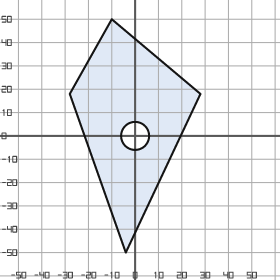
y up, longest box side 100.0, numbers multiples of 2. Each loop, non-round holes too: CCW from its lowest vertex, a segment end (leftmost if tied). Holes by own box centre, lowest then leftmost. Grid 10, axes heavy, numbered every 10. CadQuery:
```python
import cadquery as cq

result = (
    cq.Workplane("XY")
    .moveTo(-4.0, -50.0)
    .lineTo(28.0, 18.0)
    .lineTo(-10.0, 50.0)
    .lineTo(-28.0, 18.0)
    .close()
    .moveTo(0.0, 0.0)
    .circle(6.0)
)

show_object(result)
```